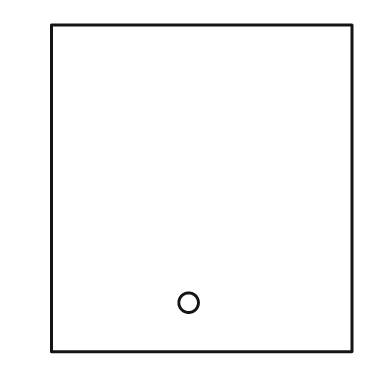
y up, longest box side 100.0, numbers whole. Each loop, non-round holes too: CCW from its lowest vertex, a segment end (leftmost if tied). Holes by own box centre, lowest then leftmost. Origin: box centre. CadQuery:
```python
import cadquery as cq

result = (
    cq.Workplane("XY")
    .moveTo(-46.0, -50.0)
    .lineTo(46.0, -50.0)
    .lineTo(46.0, 50.0)
    .lineTo(-46.0, 50.0)
    .close()
    .moveTo(-4.0, -35.0)
    .circle(3.0)
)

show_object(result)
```